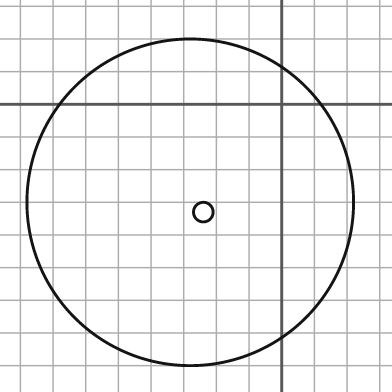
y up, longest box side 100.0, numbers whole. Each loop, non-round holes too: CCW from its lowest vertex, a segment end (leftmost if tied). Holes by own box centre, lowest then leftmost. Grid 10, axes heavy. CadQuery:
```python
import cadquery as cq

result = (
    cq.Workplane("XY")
    .moveTo(-28.0, -30.0)
    .circle(50.0)
    .moveTo(-24.0, -33.0)
    .circle(3.0)
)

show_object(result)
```